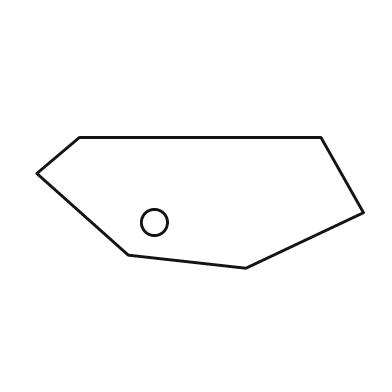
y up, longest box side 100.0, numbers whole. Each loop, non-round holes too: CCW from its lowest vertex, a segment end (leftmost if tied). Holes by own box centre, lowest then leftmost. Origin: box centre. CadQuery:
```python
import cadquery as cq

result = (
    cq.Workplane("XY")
    .moveTo(14.0, -20.0)
    .lineTo(50.0, -3.0)
    .lineTo(37.0, 20.0)
    .lineTo(-37.0, 20.0)
    .lineTo(-50.0, 9.0)
    .lineTo(-22.0, -16.0)
    .close()
    .moveTo(-14.0, -6.0)
    .circle(4.0)
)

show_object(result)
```